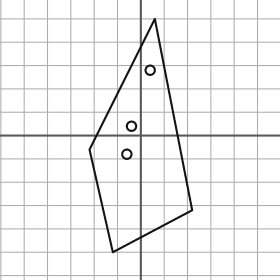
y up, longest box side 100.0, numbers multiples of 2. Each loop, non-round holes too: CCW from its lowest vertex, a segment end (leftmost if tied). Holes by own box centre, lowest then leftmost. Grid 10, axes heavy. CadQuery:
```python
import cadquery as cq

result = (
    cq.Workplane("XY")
    .moveTo(-12.0, -50.0)
    .lineTo(22.0, -32.0)
    .lineTo(6.0, 50.0)
    .lineTo(-22.0, -6.0)
    .close()
    .moveTo(-6.0, -8.0)
    .circle(2.0)
    .moveTo(-4.0, 4.0)
    .circle(2.0)
    .moveTo(4.0, 28.0)
    .circle(2.0)
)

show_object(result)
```